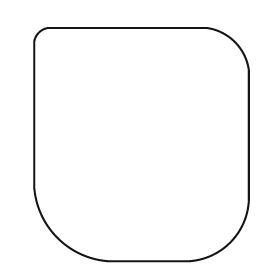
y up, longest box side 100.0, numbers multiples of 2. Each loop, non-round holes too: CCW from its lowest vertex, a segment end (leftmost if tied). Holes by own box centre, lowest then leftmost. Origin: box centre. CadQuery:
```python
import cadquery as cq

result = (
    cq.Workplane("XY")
    .moveTo(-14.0, -50.0)
    .lineTo(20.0, -50.0)
    .threePointArc((38.0, -42.0), (46.0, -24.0))
    .lineTo(46.0, 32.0)
    .threePointArc((40.0, 44.0), (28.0, 50.0))
    .lineTo(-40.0, 50.0)
    .threePointArc((-44.0, 48.0), (-46.0, 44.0))
    .lineTo(-46.0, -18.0)
    .threePointArc((-36.0, -40.0), (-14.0, -50.0))
    .close()
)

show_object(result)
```